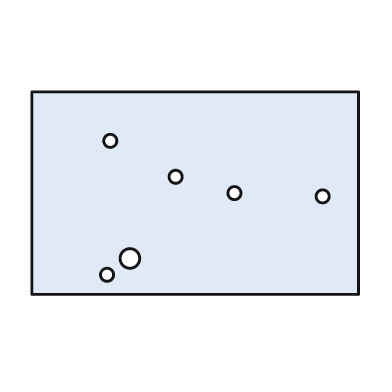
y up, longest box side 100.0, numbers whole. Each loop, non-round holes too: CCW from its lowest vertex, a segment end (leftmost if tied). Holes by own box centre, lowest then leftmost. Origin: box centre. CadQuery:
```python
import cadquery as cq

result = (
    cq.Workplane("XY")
    .moveTo(-50.0, -31.0)
    .lineTo(50.0, -31.0)
    .lineTo(50.0, 31.0)
    .lineTo(-50.0, 31.0)
    .close()
    .moveTo(-27.0, -25.0)
    .circle(2.0)
    .moveTo(-20.0, -20.0)
    .circle(3.0)
    .moveTo(39.0, -1.0)
    .circle(2.0)
    .moveTo(12.0, 0.0)
    .circle(2.0)
    .moveTo(-6.0, 5.0)
    .circle(2.0)
    .moveTo(-26.0, 16.0)
    .circle(2.0)
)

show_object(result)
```